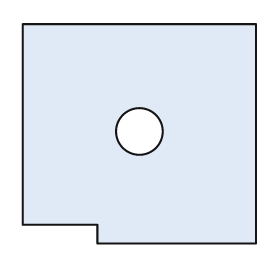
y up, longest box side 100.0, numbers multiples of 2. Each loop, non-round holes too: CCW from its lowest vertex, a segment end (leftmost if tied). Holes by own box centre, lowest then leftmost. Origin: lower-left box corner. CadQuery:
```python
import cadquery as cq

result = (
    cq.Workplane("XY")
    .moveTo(32.0, 0.0)
    .lineTo(100.0, 0.0)
    .lineTo(100.0, 94.0)
    .lineTo(0.0, 94.0)
    .lineTo(0.0, 8.0)
    .lineTo(32.0, 8.0)
    .close()
    .moveTo(50.0, 48.0)
    .circle(10.0)
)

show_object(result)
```